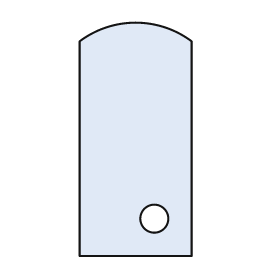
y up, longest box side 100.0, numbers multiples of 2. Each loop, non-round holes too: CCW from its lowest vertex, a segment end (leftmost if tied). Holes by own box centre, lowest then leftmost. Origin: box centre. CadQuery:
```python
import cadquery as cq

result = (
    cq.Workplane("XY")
    .moveTo(-24.0, -50.0)
    .lineTo(24.0, -50.0)
    .lineTo(24.0, 42.0)
    .threePointArc((0.0, 50.0), (-24.0, 42.0))
    .close()
    .moveTo(8.0, -34.0)
    .circle(6.0)
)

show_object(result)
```